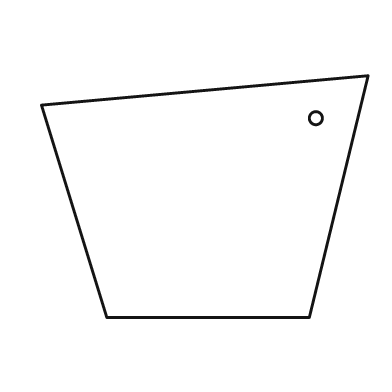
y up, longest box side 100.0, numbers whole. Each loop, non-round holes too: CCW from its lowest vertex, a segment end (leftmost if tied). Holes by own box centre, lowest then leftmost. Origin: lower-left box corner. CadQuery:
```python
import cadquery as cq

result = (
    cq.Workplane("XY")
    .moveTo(20.0, 0.0)
    .lineTo(82.0, 0.0)
    .lineTo(100.0, 74.0)
    .lineTo(0.0, 65.0)
    .close()
    .moveTo(84.0, 61.0)
    .circle(2.0)
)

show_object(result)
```